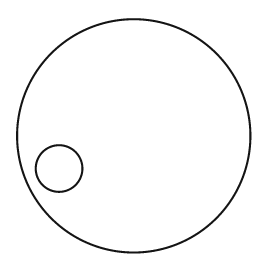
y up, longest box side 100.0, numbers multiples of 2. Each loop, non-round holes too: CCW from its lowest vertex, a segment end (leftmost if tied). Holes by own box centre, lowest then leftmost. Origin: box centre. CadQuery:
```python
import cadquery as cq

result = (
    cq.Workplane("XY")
    .moveTo(0.0, 0.0)
    .circle(50.0)
    .moveTo(-32.0, -14.0)
    .circle(10.0)
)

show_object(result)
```